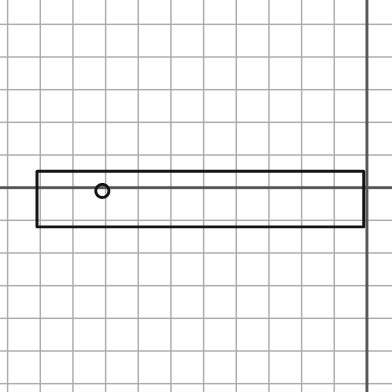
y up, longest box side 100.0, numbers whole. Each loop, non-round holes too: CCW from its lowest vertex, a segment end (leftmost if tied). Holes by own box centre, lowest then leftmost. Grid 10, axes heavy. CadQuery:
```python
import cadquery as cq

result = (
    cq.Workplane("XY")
    .moveTo(-101.0, -12.0)
    .lineTo(-1.0, -12.0)
    .lineTo(-1.0, 5.0)
    .lineTo(-101.0, 5.0)
    .close()
    .moveTo(-81.0, -1.0)
    .circle(2.0)
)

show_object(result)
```